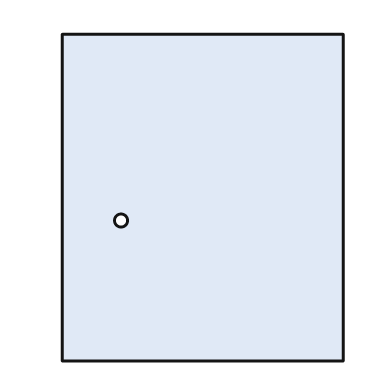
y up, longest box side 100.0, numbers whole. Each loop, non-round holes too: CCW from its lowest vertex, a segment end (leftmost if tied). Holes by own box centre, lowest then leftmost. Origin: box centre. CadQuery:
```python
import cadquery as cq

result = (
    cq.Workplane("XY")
    .moveTo(-43.0, -50.0)
    .lineTo(43.0, -50.0)
    .lineTo(43.0, 50.0)
    .lineTo(-43.0, 50.0)
    .close()
    .moveTo(-25.0, -7.0)
    .circle(2.0)
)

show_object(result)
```